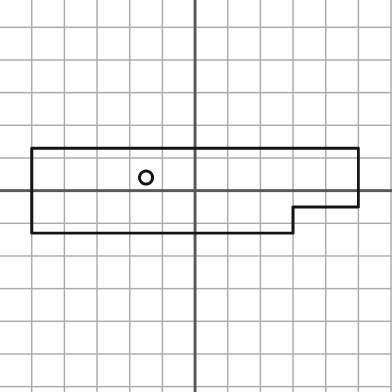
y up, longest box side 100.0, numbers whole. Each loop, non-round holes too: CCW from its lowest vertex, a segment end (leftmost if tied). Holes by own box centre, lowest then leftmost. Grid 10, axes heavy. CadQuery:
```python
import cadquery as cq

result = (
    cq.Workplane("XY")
    .moveTo(-50.0, -13.0)
    .lineTo(30.0, -13.0)
    .lineTo(30.0, -5.0)
    .lineTo(50.0, -5.0)
    .lineTo(50.0, 13.0)
    .lineTo(-50.0, 13.0)
    .close()
    .moveTo(-15.0, 4.0)
    .circle(2.0)
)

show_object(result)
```